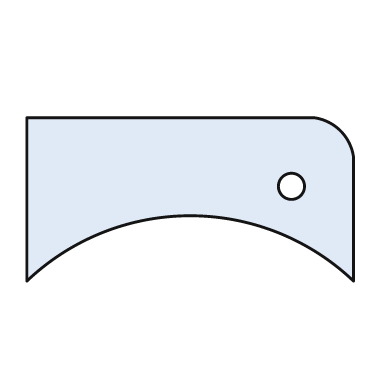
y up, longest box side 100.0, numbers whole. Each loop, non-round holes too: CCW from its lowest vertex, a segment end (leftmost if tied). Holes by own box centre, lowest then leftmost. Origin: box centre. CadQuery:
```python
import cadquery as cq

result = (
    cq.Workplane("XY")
    .moveTo(-50.0, -25.0)
    .threePointArc((0.0, -5.0), (50.0, -25.0))
    .lineTo(50.0, 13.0)
    .threePointArc((46.0, 21.0), (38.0, 25.0))
    .lineTo(-50.0, 25.0)
    .close()
    .moveTo(31.0, 4.0)
    .circle(4.0)
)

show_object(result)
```